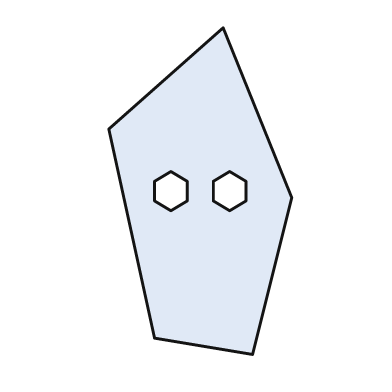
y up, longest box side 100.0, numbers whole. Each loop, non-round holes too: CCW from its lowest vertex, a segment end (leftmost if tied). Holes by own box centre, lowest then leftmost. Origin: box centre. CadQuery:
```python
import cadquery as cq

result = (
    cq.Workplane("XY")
    .moveTo(16.0, -50.0)
    .lineTo(28.0, -2.0)
    .lineTo(7.0, 50.0)
    .lineTo(-28.0, 19.0)
    .lineTo(-14.0, -45.0)
    .close()
    .moveTo(-9.0, -6.0)
    .lineTo(-4.0, -3.0)
    .lineTo(-4.0, 3.0)
    .lineTo(-9.0, 6.0)
    .lineTo(-14.0, 3.0)
    .lineTo(-14.0, -3.0)
    .close()
    .moveTo(9.0, -6.0)
    .lineTo(14.0, -3.0)
    .lineTo(14.0, 3.0)
    .lineTo(9.0, 6.0)
    .lineTo(4.0, 3.0)
    .lineTo(4.0, -3.0)
    .close()
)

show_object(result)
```